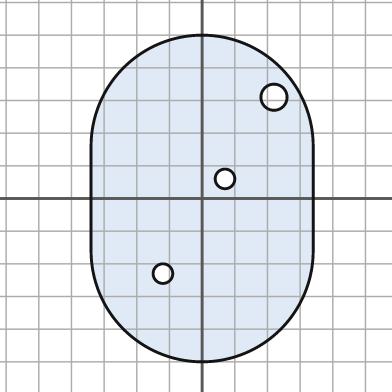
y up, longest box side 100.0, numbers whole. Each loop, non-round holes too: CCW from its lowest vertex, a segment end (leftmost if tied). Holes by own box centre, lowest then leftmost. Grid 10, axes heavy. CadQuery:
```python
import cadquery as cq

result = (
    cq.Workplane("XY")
    .moveTo(-34.0, -16.0)
    .threePointArc((0.0, -50.0), (34.0, -16.0))
    .lineTo(34.0, 16.0)
    .threePointArc((0.0, 50.0), (-34.0, 16.0))
    .close()
    .moveTo(-12.0, -23.0)
    .circle(3.0)
    .moveTo(7.0, 6.0)
    .circle(3.0)
    .moveTo(22.0, 31.0)
    .circle(4.0)
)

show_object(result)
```